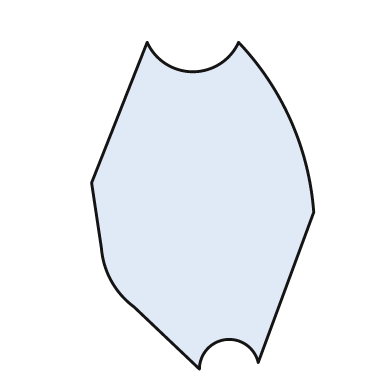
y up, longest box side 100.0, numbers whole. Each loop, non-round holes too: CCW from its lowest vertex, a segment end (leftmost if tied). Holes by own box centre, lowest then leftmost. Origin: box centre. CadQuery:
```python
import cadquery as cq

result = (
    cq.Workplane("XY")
    .moveTo(-1.0, -50.0)
    .threePointArc((7.0, -41.0), (17.0, -48.0))
    .lineTo(34.0, -2.0)
    .threePointArc((27.0, 26.0), (11.0, 50.0))
    .threePointArc((-3.0, 41.0), (-17.0, 50.0))
    .lineTo(-34.0, 7.0)
    .lineTo(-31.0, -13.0)
    .threePointArc((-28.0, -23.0), (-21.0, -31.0))
    .close()
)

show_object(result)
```